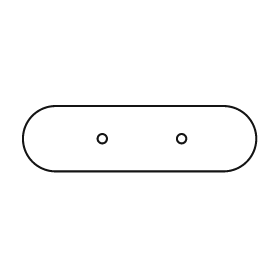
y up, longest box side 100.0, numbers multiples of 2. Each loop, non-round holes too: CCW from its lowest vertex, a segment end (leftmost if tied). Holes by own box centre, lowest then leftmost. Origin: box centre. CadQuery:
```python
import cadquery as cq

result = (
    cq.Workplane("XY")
    .moveTo(-36.0, -14.0)
    .lineTo(36.0, -14.0)
    .threePointArc((50.0, 0.0), (36.0, 14.0))
    .lineTo(-36.0, 14.0)
    .threePointArc((-50.0, 0.0), (-36.0, -14.0))
    .close()
    .moveTo(-16.0, 0.0)
    .circle(2.0)
    .moveTo(18.0, 0.0)
    .circle(2.0)
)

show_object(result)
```